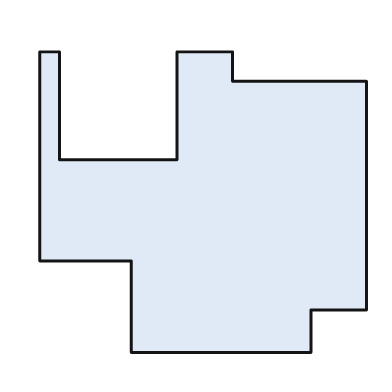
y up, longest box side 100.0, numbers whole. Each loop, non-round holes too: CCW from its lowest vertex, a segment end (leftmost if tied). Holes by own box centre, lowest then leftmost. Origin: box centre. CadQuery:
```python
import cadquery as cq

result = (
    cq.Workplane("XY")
    .moveTo(-22.0, -46.0)
    .lineTo(33.0, -46.0)
    .lineTo(33.0, -33.0)
    .lineTo(50.0, -33.0)
    .lineTo(50.0, 37.0)
    .lineTo(9.0, 37.0)
    .lineTo(9.0, 46.0)
    .lineTo(-8.0, 46.0)
    .lineTo(-8.0, 13.0)
    .lineTo(-44.0, 13.0)
    .lineTo(-44.0, 46.0)
    .lineTo(-50.0, 46.0)
    .lineTo(-50.0, -18.0)
    .lineTo(-22.0, -18.0)
    .close()
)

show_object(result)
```